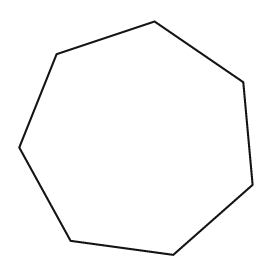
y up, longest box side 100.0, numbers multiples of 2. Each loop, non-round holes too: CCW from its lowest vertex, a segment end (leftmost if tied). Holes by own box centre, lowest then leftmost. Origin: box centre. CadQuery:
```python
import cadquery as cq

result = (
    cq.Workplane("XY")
    .moveTo(16.0, -50.0)
    .lineTo(50.0, -20.0)
    .lineTo(46.0, 24.0)
    .lineTo(8.0, 50.0)
    .lineTo(-34.0, 36.0)
    .lineTo(-50.0, -4.0)
    .lineTo(-28.0, -44.0)
    .close()
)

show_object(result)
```